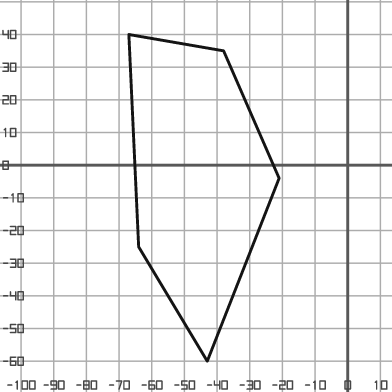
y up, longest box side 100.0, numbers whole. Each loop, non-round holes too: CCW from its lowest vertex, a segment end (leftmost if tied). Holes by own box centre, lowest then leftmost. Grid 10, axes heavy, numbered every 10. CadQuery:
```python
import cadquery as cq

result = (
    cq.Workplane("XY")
    .moveTo(-43.0, -60.0)
    .lineTo(-21.0, -4.0)
    .lineTo(-38.0, 35.0)
    .lineTo(-67.0, 40.0)
    .lineTo(-64.0, -25.0)
    .close()
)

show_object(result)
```